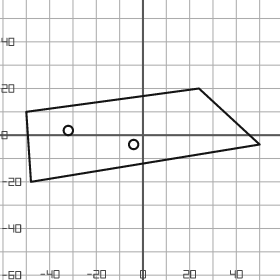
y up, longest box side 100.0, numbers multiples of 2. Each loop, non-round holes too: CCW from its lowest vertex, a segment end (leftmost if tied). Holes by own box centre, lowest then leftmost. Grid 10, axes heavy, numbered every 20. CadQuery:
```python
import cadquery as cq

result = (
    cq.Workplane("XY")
    .moveTo(-48.0, -20.0)
    .lineTo(50.0, -4.0)
    .lineTo(24.0, 20.0)
    .lineTo(-50.0, 10.0)
    .close()
    .moveTo(-4.0, -4.0)
    .circle(2.0)
    .moveTo(-32.0, 2.0)
    .circle(2.0)
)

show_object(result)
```